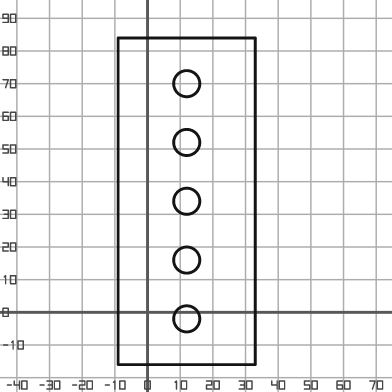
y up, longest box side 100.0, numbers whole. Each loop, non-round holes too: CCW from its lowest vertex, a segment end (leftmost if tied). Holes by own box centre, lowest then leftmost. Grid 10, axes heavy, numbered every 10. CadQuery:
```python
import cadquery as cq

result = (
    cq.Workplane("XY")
    .moveTo(-9.0, -16.0)
    .lineTo(33.0, -16.0)
    .lineTo(33.0, 84.0)
    .lineTo(-9.0, 84.0)
    .close()
    .moveTo(12.0, -2.0)
    .circle(4.0)
    .moveTo(12.0, 16.0)
    .circle(4.0)
    .moveTo(12.0, 34.0)
    .circle(4.0)
    .moveTo(12.0, 52.0)
    .circle(4.0)
    .moveTo(12.0, 70.0)
    .circle(4.0)
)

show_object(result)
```